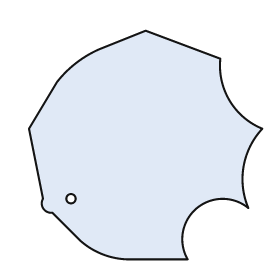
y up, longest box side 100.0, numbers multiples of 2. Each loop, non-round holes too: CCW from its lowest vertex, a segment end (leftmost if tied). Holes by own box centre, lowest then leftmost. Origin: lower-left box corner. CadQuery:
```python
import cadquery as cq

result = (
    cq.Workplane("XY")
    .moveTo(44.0, 0.0)
    .lineTo(68.0, 0.0)
    .threePointArc((72.0, 22.0), (94.0, 22.0))
    .threePointArc((92.0, 40.0), (100.0, 56.0))
    .threePointArc((86.0, 68.0), (82.0, 86.0))
    .lineTo(50.0, 98.0)
    .lineTo(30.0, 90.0)
    .threePointArc((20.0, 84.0), (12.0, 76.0))
    .lineTo(0.0, 56.0)
    .lineTo(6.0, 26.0)
    .threePointArc((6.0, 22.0), (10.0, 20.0))
    .lineTo(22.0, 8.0)
    .threePointArc((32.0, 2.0), (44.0, 0.0))
    .close()
    .moveTo(18.0, 26.0)
    .circle(2.0)
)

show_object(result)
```